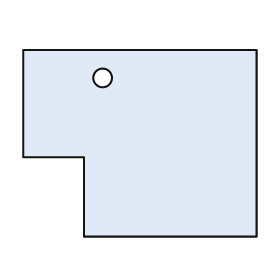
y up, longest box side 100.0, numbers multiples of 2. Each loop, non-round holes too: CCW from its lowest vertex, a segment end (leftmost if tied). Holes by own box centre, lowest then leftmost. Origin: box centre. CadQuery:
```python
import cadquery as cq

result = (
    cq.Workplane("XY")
    .moveTo(-24.0, -40.0)
    .lineTo(50.0, -40.0)
    .lineTo(50.0, 40.0)
    .lineTo(-50.0, 40.0)
    .lineTo(-50.0, -6.0)
    .lineTo(-24.0, -6.0)
    .close()
    .moveTo(-16.0, 28.0)
    .circle(4.0)
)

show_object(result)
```